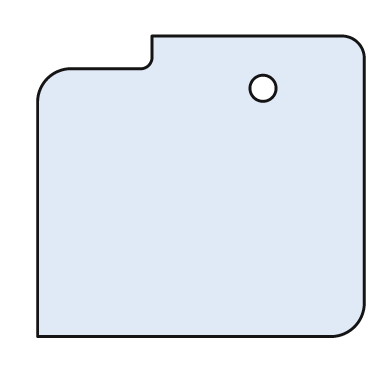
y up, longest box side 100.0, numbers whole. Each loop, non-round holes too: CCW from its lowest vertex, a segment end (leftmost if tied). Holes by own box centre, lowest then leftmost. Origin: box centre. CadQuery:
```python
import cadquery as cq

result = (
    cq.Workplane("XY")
    .moveTo(-50.0, -46.0)
    .lineTo(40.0, -46.0)
    .threePointArc((47.0, -43.0), (50.0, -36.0))
    .lineTo(50.0, 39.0)
    .threePointArc((48.0, 44.0), (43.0, 46.0))
    .lineTo(-15.0, 46.0)
    .lineTo(-15.0, 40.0)
    .threePointArc((-16.0, 37.0), (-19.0, 36.0))
    .lineTo(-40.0, 36.0)
    .threePointArc((-47.0, 33.0), (-50.0, 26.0))
    .close()
    .moveTo(19.0, 30.0)
    .circle(4.0)
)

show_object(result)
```